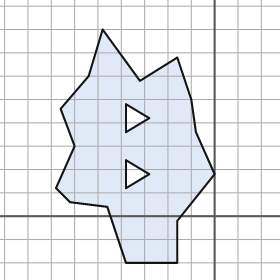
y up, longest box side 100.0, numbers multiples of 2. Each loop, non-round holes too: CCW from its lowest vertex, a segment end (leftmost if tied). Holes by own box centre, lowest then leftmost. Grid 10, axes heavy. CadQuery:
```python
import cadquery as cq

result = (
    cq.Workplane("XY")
    .moveTo(-38.0, -20.0)
    .lineTo(-16.0, -20.0)
    .lineTo(-16.0, -2.0)
    .lineTo(0.0, 18.0)
    .lineTo(-8.0, 36.0)
    .lineTo(-10.0, 50.0)
    .lineTo(-16.0, 68.0)
    .lineTo(-32.0, 58.0)
    .lineTo(-48.0, 80.0)
    .lineTo(-54.0, 60.0)
    .lineTo(-66.0, 46.0)
    .lineTo(-60.0, 30.0)
    .lineTo(-68.0, 12.0)
    .lineTo(-62.0, 6.0)
    .lineTo(-46.0, 4.0)
    .close()
    .moveTo(-38.0, 12.0)
    .lineTo(-28.0, 18.0)
    .lineTo(-38.0, 24.0)
    .close()
    .moveTo(-38.0, 36.0)
    .lineTo(-28.0, 42.0)
    .lineTo(-38.0, 48.0)
    .close()
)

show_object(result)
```